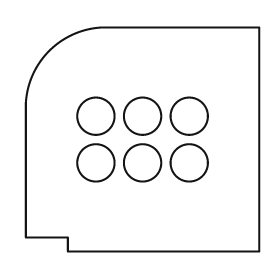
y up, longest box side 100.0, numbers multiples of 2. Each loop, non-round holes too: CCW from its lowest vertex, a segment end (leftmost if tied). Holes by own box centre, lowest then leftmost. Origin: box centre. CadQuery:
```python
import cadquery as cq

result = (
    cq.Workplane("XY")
    .moveTo(-32.0, -48.0)
    .lineTo(50.0, -48.0)
    .lineTo(50.0, 48.0)
    .lineTo(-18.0, 48.0)
    .threePointArc((-40.0, 38.0), (-50.0, 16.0))
    .lineTo(-50.0, -42.0)
    .lineTo(-32.0, -42.0)
    .close()
    .moveTo(-20.0, -10.0)
    .circle(8.0)
    .moveTo(0.0, -10.0)
    .circle(8.0)
    .moveTo(20.0, -10.0)
    .circle(8.0)
    .moveTo(-20.0, 10.0)
    .circle(8.0)
    .moveTo(0.0, 10.0)
    .circle(8.0)
    .moveTo(20.0, 10.0)
    .circle(8.0)
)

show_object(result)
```